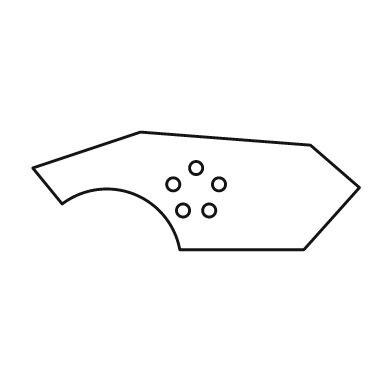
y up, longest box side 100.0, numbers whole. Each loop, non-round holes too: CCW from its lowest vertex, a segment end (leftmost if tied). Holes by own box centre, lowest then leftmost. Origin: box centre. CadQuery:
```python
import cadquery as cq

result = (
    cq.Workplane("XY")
    .moveTo(-5.0, -18.0)
    .lineTo(33.0, -18.0)
    .lineTo(50.0, 1.0)
    .lineTo(35.0, 14.0)
    .lineTo(-17.0, 18.0)
    .lineTo(-50.0, 7.0)
    .lineTo(-41.0, -4.0)
    .threePointArc((-19.0, -1.0), (-5.0, -18.0))
    .close()
    .moveTo(-4.0, -6.0)
    .circle(2.0)
    .moveTo(4.0, -6.0)
    .circle(2.0)
    .moveTo(-7.0, 2.0)
    .circle(2.0)
    .moveTo(7.0, 2.0)
    .circle(2.0)
    .moveTo(0.0, 7.0)
    .circle(2.0)
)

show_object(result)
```